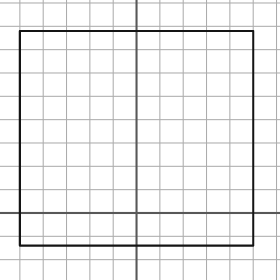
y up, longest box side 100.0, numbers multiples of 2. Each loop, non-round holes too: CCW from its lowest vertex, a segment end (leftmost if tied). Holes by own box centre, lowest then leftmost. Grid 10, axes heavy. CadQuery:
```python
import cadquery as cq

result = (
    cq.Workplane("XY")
    .moveTo(-50.0, -14.0)
    .lineTo(50.0, -14.0)
    .lineTo(50.0, 78.0)
    .lineTo(-50.0, 78.0)
    .close()
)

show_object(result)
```